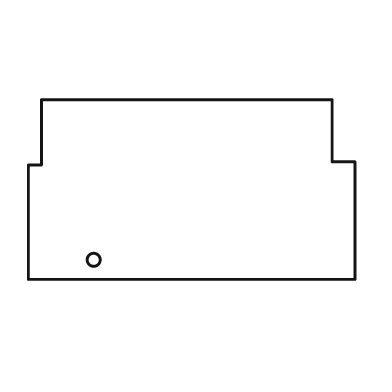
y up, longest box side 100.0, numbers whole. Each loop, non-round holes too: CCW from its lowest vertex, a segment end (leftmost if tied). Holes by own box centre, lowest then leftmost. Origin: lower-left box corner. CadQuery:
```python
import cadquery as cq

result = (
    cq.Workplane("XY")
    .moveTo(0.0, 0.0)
    .lineTo(100.0, 0.0)
    .lineTo(100.0, 36.0)
    .lineTo(93.0, 36.0)
    .lineTo(93.0, 55.0)
    .lineTo(4.0, 55.0)
    .lineTo(4.0, 35.0)
    .lineTo(0.0, 35.0)
    .close()
    .moveTo(20.0, 6.0)
    .circle(2.0)
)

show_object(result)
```